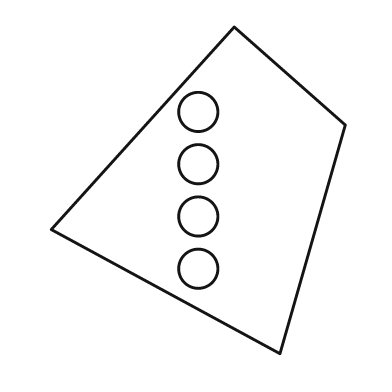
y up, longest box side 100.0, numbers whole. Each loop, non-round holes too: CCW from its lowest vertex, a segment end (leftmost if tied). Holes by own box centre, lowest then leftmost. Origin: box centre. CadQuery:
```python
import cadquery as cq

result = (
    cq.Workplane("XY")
    .moveTo(25.0, -50.0)
    .lineTo(45.0, 20.0)
    .lineTo(11.0, 50.0)
    .lineTo(-45.0, -12.0)
    .close()
    .moveTo(0.0, -24.0)
    .circle(6.0)
    .moveTo(0.0, -8.0)
    .circle(6.0)
    .moveTo(0.0, 8.0)
    .circle(6.0)
    .moveTo(0.0, 24.0)
    .circle(6.0)
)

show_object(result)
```